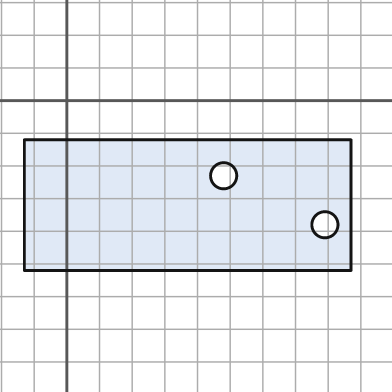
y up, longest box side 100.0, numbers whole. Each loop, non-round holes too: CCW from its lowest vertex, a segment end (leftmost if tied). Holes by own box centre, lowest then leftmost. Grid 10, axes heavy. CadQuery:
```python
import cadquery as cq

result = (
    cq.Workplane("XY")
    .moveTo(-13.0, -52.0)
    .lineTo(87.0, -52.0)
    .lineTo(87.0, -12.0)
    .lineTo(-13.0, -12.0)
    .close()
    .moveTo(79.0, -38.0)
    .circle(4.0)
    .moveTo(48.0, -23.0)
    .circle(4.0)
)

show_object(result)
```